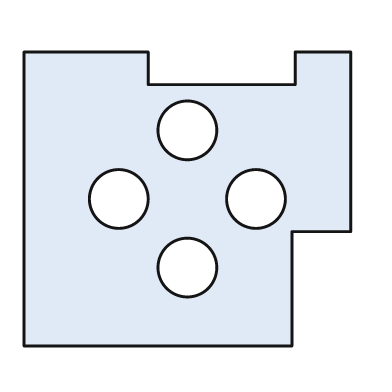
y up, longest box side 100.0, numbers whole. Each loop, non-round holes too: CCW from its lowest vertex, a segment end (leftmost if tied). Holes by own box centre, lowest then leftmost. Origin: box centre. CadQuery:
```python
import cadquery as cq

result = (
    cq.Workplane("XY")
    .moveTo(-50.0, -45.0)
    .lineTo(32.0, -45.0)
    .lineTo(32.0, -10.0)
    .lineTo(50.0, -10.0)
    .lineTo(50.0, 45.0)
    .lineTo(33.0, 45.0)
    .lineTo(33.0, 35.0)
    .lineTo(-12.0, 35.0)
    .lineTo(-12.0, 45.0)
    .lineTo(-50.0, 45.0)
    .close()
    .moveTo(0.0, -21.0)
    .circle(9.0)
    .moveTo(-21.0, 0.0)
    .circle(9.0)
    .moveTo(21.0, 0.0)
    .circle(9.0)
    .moveTo(0.0, 21.0)
    .circle(9.0)
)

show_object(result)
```